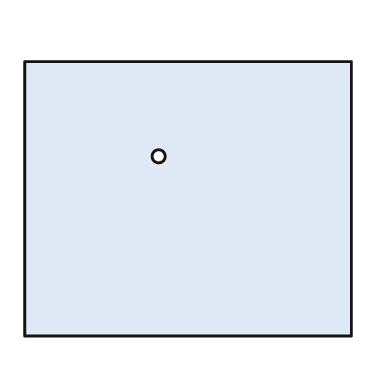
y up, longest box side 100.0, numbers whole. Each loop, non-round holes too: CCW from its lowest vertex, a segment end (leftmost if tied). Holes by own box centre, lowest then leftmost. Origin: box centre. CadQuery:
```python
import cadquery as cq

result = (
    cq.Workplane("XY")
    .moveTo(-50.0, -42.0)
    .lineTo(50.0, -42.0)
    .lineTo(50.0, 42.0)
    .lineTo(-50.0, 42.0)
    .close()
    .moveTo(-9.0, 13.0)
    .circle(2.0)
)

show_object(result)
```